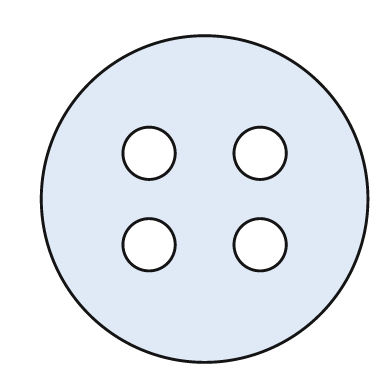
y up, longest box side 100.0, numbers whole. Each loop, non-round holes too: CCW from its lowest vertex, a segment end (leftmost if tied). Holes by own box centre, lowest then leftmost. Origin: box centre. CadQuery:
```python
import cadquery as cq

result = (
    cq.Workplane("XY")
    .moveTo(0.0, 0.0)
    .circle(50.0)
    .moveTo(-17.0, -14.0)
    .circle(8.0)
    .moveTo(17.0, -14.0)
    .circle(8.0)
    .moveTo(-17.0, 14.0)
    .circle(8.0)
    .moveTo(17.0, 14.0)
    .circle(8.0)
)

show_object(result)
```